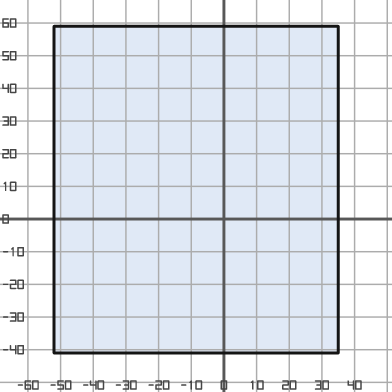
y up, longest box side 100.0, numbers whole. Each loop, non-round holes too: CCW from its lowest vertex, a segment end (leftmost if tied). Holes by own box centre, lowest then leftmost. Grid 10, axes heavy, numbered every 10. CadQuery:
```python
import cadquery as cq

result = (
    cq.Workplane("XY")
    .moveTo(-52.0, -41.0)
    .lineTo(35.0, -41.0)
    .lineTo(35.0, 59.0)
    .lineTo(-52.0, 59.0)
    .close()
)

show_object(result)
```